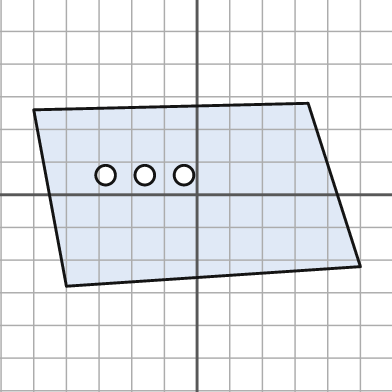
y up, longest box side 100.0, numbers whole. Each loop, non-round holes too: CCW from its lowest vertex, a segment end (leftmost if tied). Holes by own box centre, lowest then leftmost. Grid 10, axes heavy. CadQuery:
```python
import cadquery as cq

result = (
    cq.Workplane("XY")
    .moveTo(-40.0, -28.0)
    .lineTo(50.0, -22.0)
    .lineTo(34.0, 28.0)
    .lineTo(-50.0, 26.0)
    .close()
    .moveTo(-28.0, 6.0)
    .circle(3.0)
    .moveTo(-16.0, 6.0)
    .circle(3.0)
    .moveTo(-4.0, 6.0)
    .circle(3.0)
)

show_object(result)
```